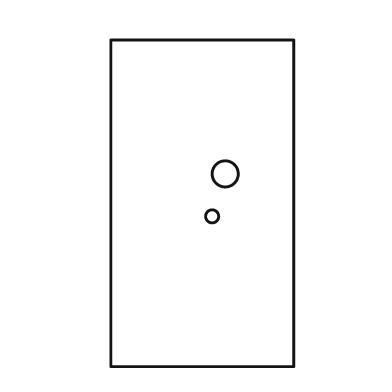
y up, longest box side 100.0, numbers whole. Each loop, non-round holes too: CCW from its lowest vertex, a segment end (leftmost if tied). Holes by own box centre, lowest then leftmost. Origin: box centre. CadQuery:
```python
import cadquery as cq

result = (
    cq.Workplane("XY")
    .moveTo(-28.0, -50.0)
    .lineTo(28.0, -50.0)
    .lineTo(28.0, 50.0)
    .lineTo(-28.0, 50.0)
    .close()
    .moveTo(3.0, -4.0)
    .circle(2.0)
    .moveTo(7.0, 9.0)
    .circle(4.0)
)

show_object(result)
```